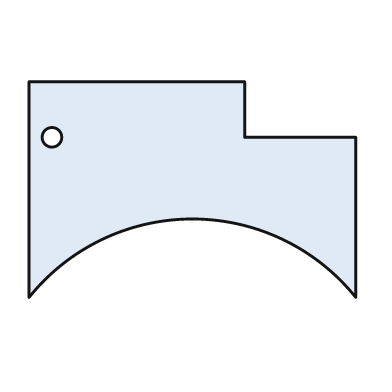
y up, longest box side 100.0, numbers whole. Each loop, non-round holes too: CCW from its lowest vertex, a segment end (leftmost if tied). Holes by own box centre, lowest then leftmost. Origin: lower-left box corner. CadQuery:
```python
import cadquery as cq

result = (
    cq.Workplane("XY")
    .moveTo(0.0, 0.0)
    .threePointArc((50.0, 24.0), (100.0, 0.0))
    .lineTo(100.0, 49.0)
    .lineTo(66.0, 49.0)
    .lineTo(66.0, 66.0)
    .lineTo(0.0, 66.0)
    .close()
    .moveTo(7.0, 49.0)
    .circle(3.0)
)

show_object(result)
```